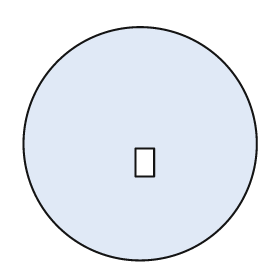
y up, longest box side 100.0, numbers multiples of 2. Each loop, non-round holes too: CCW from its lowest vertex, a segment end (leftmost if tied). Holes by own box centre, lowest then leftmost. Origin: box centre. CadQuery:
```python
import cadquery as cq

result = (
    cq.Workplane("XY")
    .moveTo(0.0, 0.0)
    .circle(50.0)
    .moveTo(-2.0, -14.0)
    .lineTo(6.0, -14.0)
    .lineTo(6.0, -2.0)
    .lineTo(-2.0, -2.0)
    .close()
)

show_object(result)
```